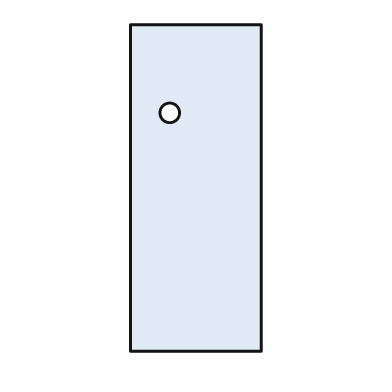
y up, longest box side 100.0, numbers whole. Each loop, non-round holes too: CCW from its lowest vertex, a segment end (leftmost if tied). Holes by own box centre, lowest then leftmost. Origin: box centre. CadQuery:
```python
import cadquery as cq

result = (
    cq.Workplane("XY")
    .moveTo(-20.0, -50.0)
    .lineTo(20.0, -50.0)
    .lineTo(20.0, 50.0)
    .lineTo(-20.0, 50.0)
    .close()
    .moveTo(-8.0, 23.0)
    .circle(3.0)
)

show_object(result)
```